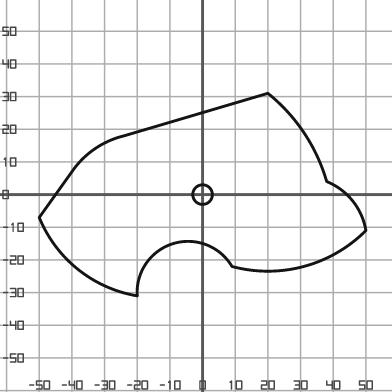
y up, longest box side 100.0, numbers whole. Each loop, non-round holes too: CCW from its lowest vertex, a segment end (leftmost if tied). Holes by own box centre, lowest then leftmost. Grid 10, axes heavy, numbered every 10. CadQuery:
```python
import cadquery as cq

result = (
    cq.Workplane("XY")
    .moveTo(-20.0, -31.0)
    .threePointArc((-9.0, -15.0), (9.0, -22.0))
    .threePointArc((31.0, -22.0), (50.0, -11.0))
    .threePointArc((46.0, -2.0), (38.0, 4.0))
    .threePointArc((31.0, 19.0), (20.0, 31.0))
    .lineTo(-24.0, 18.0)
    .threePointArc((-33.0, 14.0), (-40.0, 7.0))
    .lineTo(-50.0, -7.0)
    .threePointArc((-38.0, -23.0), (-20.0, -31.0))
    .close()
    .moveTo(0.0, 0.0)
    .circle(3.0)
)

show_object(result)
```